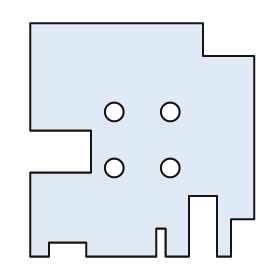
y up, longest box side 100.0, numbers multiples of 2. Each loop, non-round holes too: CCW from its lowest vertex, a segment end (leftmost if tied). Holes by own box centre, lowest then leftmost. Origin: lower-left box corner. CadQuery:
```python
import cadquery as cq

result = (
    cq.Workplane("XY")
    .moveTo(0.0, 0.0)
    .lineTo(8.0, 0.0)
    .lineTo(8.0, 6.0)
    .lineTo(24.0, 6.0)
    .lineTo(24.0, 0.0)
    .lineTo(54.0, 0.0)
    .lineTo(54.0, 12.0)
    .lineTo(58.0, 12.0)
    .lineTo(58.0, 0.0)
    .lineTo(68.0, 0.0)
    .lineTo(68.0, 26.0)
    .lineTo(80.0, 26.0)
    .lineTo(80.0, 0.0)
    .lineTo(86.0, 0.0)
    .lineTo(86.0, 16.0)
    .lineTo(96.0, 16.0)
    .lineTo(96.0, 86.0)
    .lineTo(74.0, 86.0)
    .lineTo(74.0, 100.0)
    .lineTo(0.0, 100.0)
    .lineTo(0.0, 54.0)
    .lineTo(26.0, 54.0)
    .lineTo(26.0, 36.0)
    .lineTo(0.0, 36.0)
    .close()
    .moveTo(36.0, 38.0)
    .circle(4.0)
    .moveTo(60.0, 38.0)
    .circle(4.0)
    .moveTo(36.0, 62.0)
    .circle(4.0)
    .moveTo(60.0, 62.0)
    .circle(4.0)
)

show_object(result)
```